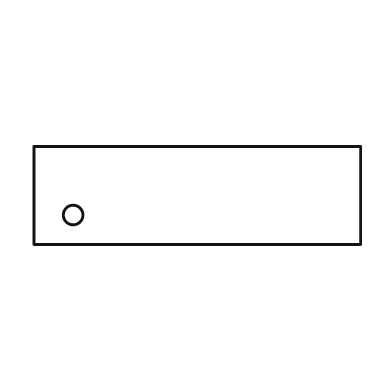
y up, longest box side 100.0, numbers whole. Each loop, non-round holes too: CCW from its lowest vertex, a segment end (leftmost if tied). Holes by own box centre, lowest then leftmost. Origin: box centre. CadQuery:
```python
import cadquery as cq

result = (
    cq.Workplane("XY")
    .moveTo(-50.0, -15.0)
    .lineTo(50.0, -15.0)
    .lineTo(50.0, 15.0)
    .lineTo(-50.0, 15.0)
    .close()
    .moveTo(-38.0, -6.0)
    .circle(3.0)
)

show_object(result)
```